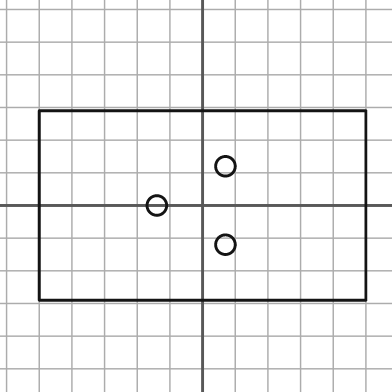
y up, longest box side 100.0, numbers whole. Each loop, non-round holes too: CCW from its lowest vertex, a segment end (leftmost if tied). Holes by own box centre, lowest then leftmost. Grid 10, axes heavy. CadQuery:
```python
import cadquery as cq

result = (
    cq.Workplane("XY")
    .moveTo(-50.0, -29.0)
    .lineTo(50.0, -29.0)
    .lineTo(50.0, 29.0)
    .lineTo(-50.0, 29.0)
    .close()
    .moveTo(7.0, -12.0)
    .circle(3.0)
    .moveTo(-14.0, 0.0)
    .circle(3.0)
    .moveTo(7.0, 12.0)
    .circle(3.0)
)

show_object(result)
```